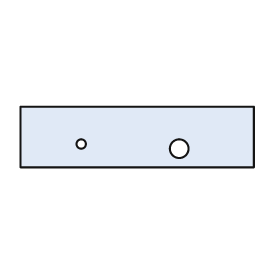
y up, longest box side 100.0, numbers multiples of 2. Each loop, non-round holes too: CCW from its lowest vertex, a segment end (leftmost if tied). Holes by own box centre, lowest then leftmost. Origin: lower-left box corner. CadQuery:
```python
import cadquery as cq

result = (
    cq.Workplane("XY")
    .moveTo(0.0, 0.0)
    .lineTo(100.0, 0.0)
    .lineTo(100.0, 26.0)
    .lineTo(0.0, 26.0)
    .close()
    .moveTo(68.0, 8.0)
    .circle(4.0)
    .moveTo(26.0, 10.0)
    .circle(2.0)
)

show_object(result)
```